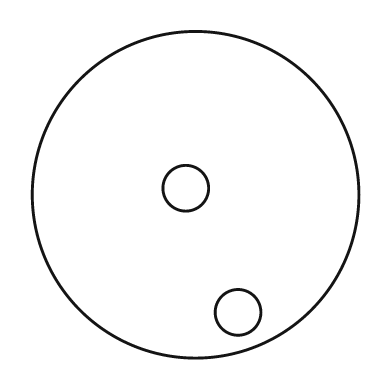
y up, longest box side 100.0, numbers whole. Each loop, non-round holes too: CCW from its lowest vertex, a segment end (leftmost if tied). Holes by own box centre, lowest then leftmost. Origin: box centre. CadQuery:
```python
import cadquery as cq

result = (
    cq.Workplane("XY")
    .moveTo(0.0, 0.0)
    .circle(50.0)
    .moveTo(13.0, -36.0)
    .circle(7.0)
    .moveTo(-3.0, 2.0)
    .circle(7.0)
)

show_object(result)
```